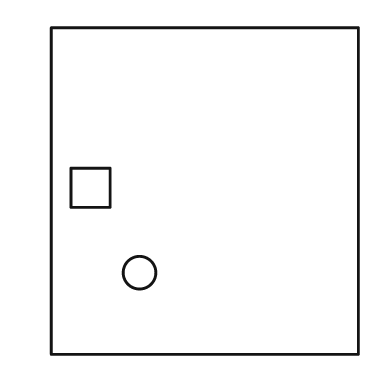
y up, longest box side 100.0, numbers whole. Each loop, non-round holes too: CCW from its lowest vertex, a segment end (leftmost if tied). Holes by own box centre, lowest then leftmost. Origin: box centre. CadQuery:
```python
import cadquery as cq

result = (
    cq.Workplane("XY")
    .moveTo(-47.0, -50.0)
    .lineTo(47.0, -50.0)
    .lineTo(47.0, 50.0)
    .lineTo(-47.0, 50.0)
    .close()
    .moveTo(-20.0, -25.0)
    .circle(5.0)
    .moveTo(-41.0, -5.0)
    .lineTo(-29.0, -5.0)
    .lineTo(-29.0, 7.0)
    .lineTo(-41.0, 7.0)
    .close()
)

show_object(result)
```